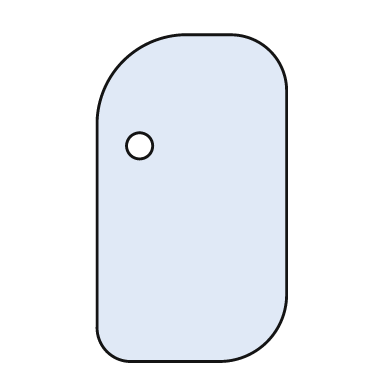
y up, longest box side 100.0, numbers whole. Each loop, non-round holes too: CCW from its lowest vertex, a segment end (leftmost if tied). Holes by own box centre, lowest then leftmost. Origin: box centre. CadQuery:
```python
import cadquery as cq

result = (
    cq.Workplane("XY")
    .moveTo(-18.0, -50.0)
    .lineTo(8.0, -50.0)
    .threePointArc((23.0, -44.0), (29.0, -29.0))
    .lineTo(29.0, 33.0)
    .threePointArc((24.0, 45.0), (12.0, 50.0))
    .lineTo(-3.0, 50.0)
    .threePointArc((-21.0, 42.0), (-29.0, 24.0))
    .lineTo(-29.0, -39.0)
    .threePointArc((-26.0, -47.0), (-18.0, -50.0))
    .close()
    .moveTo(-16.0, 16.0)
    .circle(4.0)
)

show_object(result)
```